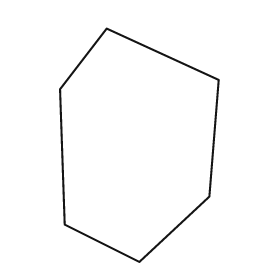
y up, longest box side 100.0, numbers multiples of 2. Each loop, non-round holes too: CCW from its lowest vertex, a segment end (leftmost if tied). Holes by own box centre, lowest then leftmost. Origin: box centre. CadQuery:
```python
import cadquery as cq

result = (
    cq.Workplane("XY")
    .moveTo(0.0, -50.0)
    .lineTo(30.0, -22.0)
    .lineTo(34.0, 28.0)
    .lineTo(-14.0, 50.0)
    .lineTo(-34.0, 24.0)
    .lineTo(-32.0, -34.0)
    .close()
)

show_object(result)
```